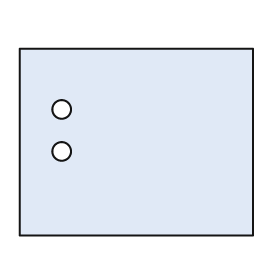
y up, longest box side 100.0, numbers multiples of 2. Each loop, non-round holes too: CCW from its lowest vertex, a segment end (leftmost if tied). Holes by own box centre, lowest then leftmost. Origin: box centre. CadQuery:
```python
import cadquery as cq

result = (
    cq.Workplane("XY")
    .moveTo(-50.0, -40.0)
    .lineTo(50.0, -40.0)
    .lineTo(50.0, 40.0)
    .lineTo(-50.0, 40.0)
    .close()
    .moveTo(-32.0, -4.0)
    .circle(4.0)
    .moveTo(-32.0, 14.0)
    .circle(4.0)
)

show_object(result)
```